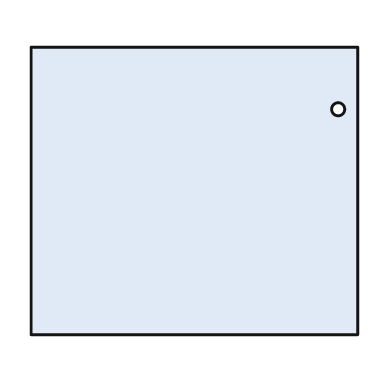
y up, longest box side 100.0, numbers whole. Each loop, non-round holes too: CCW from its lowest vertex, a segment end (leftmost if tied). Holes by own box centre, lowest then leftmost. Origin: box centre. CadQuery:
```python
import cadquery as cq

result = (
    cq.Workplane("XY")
    .moveTo(-50.0, -44.0)
    .lineTo(50.0, -44.0)
    .lineTo(50.0, 44.0)
    .lineTo(-50.0, 44.0)
    .close()
    .moveTo(44.0, 25.0)
    .circle(2.0)
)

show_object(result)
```